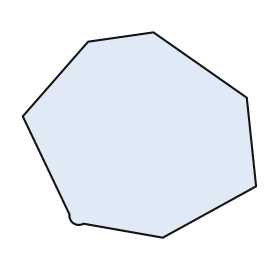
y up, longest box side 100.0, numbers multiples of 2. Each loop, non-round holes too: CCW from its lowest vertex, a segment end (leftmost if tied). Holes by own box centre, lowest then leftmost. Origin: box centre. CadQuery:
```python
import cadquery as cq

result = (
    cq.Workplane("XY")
    .moveTo(10.0, -44.0)
    .lineTo(50.0, -22.0)
    .lineTo(46.0, 16.0)
    .lineTo(6.0, 44.0)
    .lineTo(-22.0, 40.0)
    .lineTo(-50.0, 8.0)
    .lineTo(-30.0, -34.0)
    .threePointArc((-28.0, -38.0), (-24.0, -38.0))
    .close()
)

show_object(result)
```